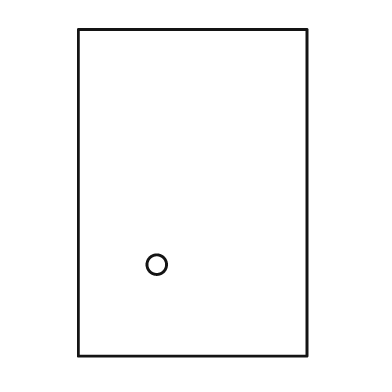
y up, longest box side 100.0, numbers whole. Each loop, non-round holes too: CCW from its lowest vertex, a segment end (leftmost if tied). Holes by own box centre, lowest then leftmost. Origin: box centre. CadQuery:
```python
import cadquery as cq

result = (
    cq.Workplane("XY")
    .moveTo(-35.0, -50.0)
    .lineTo(35.0, -50.0)
    .lineTo(35.0, 50.0)
    .lineTo(-35.0, 50.0)
    .close()
    .moveTo(-11.0, -22.0)
    .circle(3.0)
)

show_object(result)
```